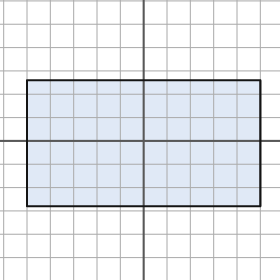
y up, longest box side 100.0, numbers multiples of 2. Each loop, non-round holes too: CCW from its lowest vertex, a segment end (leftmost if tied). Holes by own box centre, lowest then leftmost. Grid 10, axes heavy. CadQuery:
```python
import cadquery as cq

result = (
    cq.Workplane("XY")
    .moveTo(-50.0, -28.0)
    .lineTo(50.0, -28.0)
    .lineTo(50.0, 26.0)
    .lineTo(-50.0, 26.0)
    .close()
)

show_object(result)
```